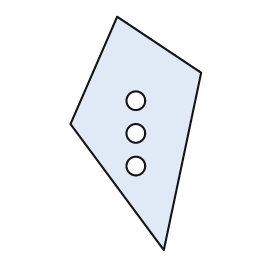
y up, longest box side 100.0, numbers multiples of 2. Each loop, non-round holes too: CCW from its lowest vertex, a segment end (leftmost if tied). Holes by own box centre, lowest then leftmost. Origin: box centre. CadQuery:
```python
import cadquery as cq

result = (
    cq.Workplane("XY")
    .moveTo(12.0, -50.0)
    .lineTo(28.0, 26.0)
    .lineTo(-8.0, 50.0)
    .lineTo(-28.0, 4.0)
    .close()
    .moveTo(0.0, -14.0)
    .circle(4.0)
    .moveTo(0.0, 0.0)
    .circle(4.0)
    .moveTo(0.0, 14.0)
    .circle(4.0)
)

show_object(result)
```